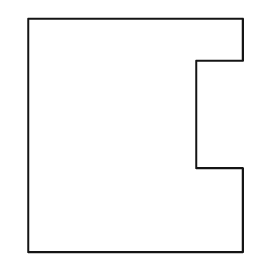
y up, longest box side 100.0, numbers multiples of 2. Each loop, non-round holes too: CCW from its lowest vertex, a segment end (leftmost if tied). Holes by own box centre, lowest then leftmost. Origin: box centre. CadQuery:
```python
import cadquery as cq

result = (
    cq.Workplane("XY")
    .moveTo(-46.0, -50.0)
    .lineTo(46.0, -50.0)
    .lineTo(46.0, -14.0)
    .lineTo(26.0, -14.0)
    .lineTo(26.0, 32.0)
    .lineTo(46.0, 32.0)
    .lineTo(46.0, 50.0)
    .lineTo(-46.0, 50.0)
    .close()
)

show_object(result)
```